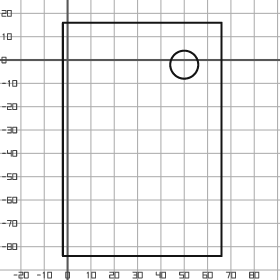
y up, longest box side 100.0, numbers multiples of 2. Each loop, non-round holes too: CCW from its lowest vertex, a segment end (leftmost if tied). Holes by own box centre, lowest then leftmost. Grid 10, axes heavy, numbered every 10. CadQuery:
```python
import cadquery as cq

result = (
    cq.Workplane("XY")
    .moveTo(-2.0, -84.0)
    .lineTo(66.0, -84.0)
    .lineTo(66.0, 16.0)
    .lineTo(-2.0, 16.0)
    .close()
    .moveTo(50.0, -2.0)
    .circle(6.0)
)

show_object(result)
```